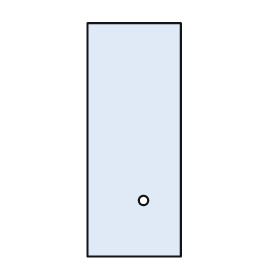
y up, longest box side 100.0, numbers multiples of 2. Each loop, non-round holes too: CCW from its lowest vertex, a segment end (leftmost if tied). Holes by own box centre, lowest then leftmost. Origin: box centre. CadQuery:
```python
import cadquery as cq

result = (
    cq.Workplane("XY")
    .moveTo(-20.0, -50.0)
    .lineTo(20.0, -50.0)
    .lineTo(20.0, 50.0)
    .lineTo(-20.0, 50.0)
    .close()
    .moveTo(4.0, -26.0)
    .circle(2.0)
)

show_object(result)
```